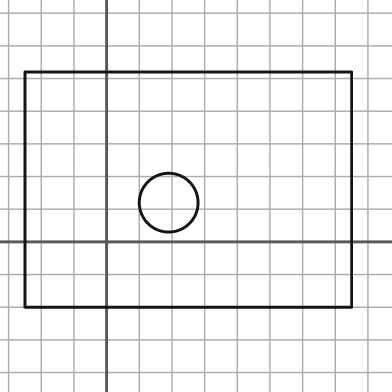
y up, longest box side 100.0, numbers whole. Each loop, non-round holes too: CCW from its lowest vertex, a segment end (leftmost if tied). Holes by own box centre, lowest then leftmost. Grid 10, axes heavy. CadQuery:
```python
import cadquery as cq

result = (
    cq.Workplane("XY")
    .moveTo(-25.0, -20.0)
    .lineTo(75.0, -20.0)
    .lineTo(75.0, 52.0)
    .lineTo(-25.0, 52.0)
    .close()
    .moveTo(19.0, 12.0)
    .circle(9.0)
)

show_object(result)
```